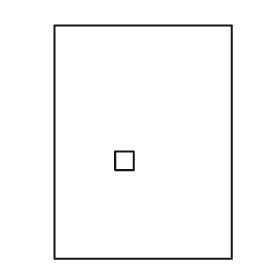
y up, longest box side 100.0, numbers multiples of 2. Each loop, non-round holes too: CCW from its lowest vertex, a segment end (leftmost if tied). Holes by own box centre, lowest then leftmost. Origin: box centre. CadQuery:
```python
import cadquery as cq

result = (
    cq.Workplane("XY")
    .moveTo(-38.0, -50.0)
    .lineTo(38.0, -50.0)
    .lineTo(38.0, 50.0)
    .lineTo(-38.0, 50.0)
    .close()
    .moveTo(-12.0, -12.0)
    .lineTo(-4.0, -12.0)
    .lineTo(-4.0, -4.0)
    .lineTo(-12.0, -4.0)
    .close()
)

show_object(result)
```